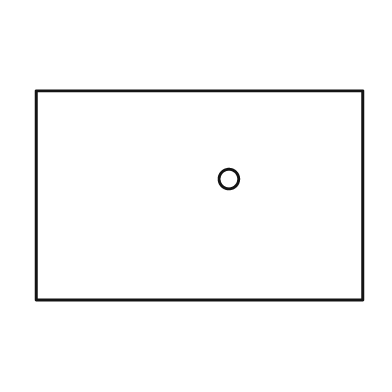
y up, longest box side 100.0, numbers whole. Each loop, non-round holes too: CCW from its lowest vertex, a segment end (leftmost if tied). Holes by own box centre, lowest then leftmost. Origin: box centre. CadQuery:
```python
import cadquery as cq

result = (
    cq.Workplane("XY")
    .moveTo(-50.0, -32.0)
    .lineTo(50.0, -32.0)
    .lineTo(50.0, 32.0)
    .lineTo(-50.0, 32.0)
    .close()
    .moveTo(9.0, 5.0)
    .circle(3.0)
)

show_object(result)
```